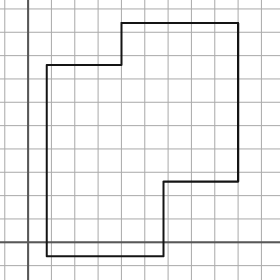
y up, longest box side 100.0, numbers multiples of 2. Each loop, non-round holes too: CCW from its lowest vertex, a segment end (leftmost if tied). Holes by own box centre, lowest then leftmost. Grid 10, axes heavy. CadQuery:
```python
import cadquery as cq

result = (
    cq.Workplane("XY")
    .moveTo(8.0, -6.0)
    .lineTo(58.0, -6.0)
    .lineTo(58.0, 26.0)
    .lineTo(90.0, 26.0)
    .lineTo(90.0, 94.0)
    .lineTo(40.0, 94.0)
    .lineTo(40.0, 76.0)
    .lineTo(8.0, 76.0)
    .close()
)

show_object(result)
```